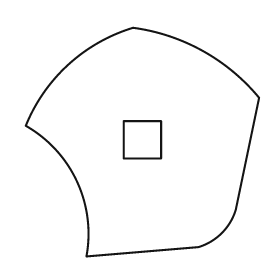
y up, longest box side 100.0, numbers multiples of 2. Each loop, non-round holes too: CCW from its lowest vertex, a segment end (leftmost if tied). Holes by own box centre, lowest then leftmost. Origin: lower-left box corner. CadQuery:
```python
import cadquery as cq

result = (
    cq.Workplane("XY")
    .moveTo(26.0, 0.0)
    .lineTo(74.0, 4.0)
    .threePointArc((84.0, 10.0), (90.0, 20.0))
    .lineTo(100.0, 68.0)
    .threePointArc((76.0, 88.0), (46.0, 98.0))
    .threePointArc((18.0, 82.0), (0.0, 56.0))
    .threePointArc((22.0, 32.0), (26.0, 0.0))
    .close()
    .moveTo(42.0, 42.0)
    .lineTo(58.0, 42.0)
    .lineTo(58.0, 58.0)
    .lineTo(42.0, 58.0)
    .close()
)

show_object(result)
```